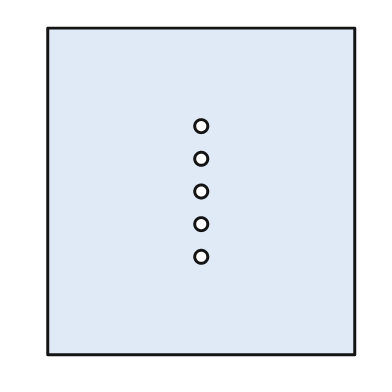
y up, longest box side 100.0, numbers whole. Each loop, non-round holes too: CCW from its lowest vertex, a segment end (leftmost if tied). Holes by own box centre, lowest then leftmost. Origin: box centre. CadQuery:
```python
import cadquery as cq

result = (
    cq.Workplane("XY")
    .moveTo(-47.0, -50.0)
    .lineTo(47.0, -50.0)
    .lineTo(47.0, 50.0)
    .lineTo(-47.0, 50.0)
    .close()
    .moveTo(0.0, -20.0)
    .circle(2.0)
    .moveTo(0.0, -10.0)
    .circle(2.0)
    .moveTo(0.0, 0.0)
    .circle(2.0)
    .moveTo(0.0, 10.0)
    .circle(2.0)
    .moveTo(0.0, 20.0)
    .circle(2.0)
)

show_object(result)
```